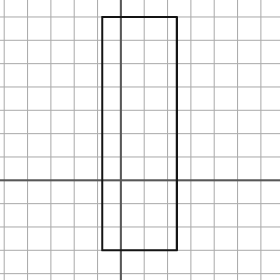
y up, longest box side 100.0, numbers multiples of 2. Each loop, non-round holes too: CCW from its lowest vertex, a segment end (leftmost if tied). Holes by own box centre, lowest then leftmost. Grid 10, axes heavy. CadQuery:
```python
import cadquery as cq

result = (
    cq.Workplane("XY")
    .moveTo(-8.0, -30.0)
    .lineTo(24.0, -30.0)
    .lineTo(24.0, 70.0)
    .lineTo(-8.0, 70.0)
    .close()
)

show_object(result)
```